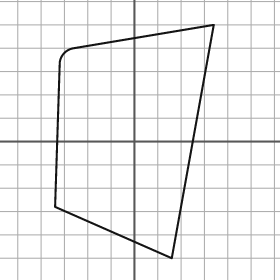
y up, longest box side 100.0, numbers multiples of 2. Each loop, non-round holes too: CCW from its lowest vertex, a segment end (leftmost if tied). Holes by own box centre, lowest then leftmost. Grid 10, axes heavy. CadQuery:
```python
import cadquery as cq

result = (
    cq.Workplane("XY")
    .moveTo(16.0, -50.0)
    .lineTo(34.0, 50.0)
    .lineTo(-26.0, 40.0)
    .threePointArc((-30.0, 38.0), (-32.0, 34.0))
    .lineTo(-34.0, -28.0)
    .close()
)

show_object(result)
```